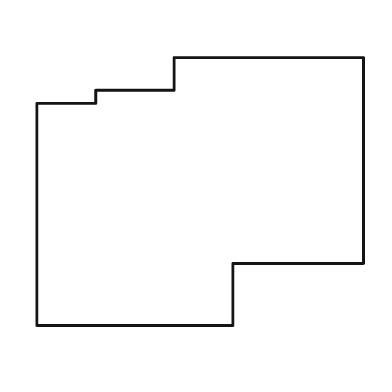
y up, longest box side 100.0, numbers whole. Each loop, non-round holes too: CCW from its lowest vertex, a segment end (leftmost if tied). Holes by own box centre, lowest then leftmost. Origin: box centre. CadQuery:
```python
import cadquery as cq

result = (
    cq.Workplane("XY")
    .moveTo(-50.0, -41.0)
    .lineTo(10.0, -41.0)
    .lineTo(10.0, -22.0)
    .lineTo(50.0, -22.0)
    .lineTo(50.0, 41.0)
    .lineTo(-8.0, 41.0)
    .lineTo(-8.0, 31.0)
    .lineTo(-32.0, 31.0)
    .lineTo(-32.0, 27.0)
    .lineTo(-50.0, 27.0)
    .close()
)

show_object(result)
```